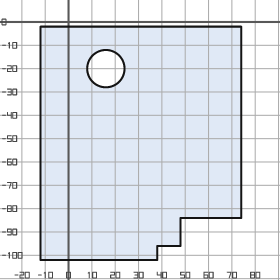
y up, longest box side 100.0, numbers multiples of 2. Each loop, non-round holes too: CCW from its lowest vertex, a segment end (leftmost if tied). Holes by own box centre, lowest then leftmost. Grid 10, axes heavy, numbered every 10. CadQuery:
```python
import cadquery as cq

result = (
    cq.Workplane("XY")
    .moveTo(-12.0, -102.0)
    .lineTo(38.0, -102.0)
    .lineTo(38.0, -96.0)
    .lineTo(48.0, -96.0)
    .lineTo(48.0, -84.0)
    .lineTo(74.0, -84.0)
    .lineTo(74.0, -2.0)
    .lineTo(-12.0, -2.0)
    .close()
    .moveTo(16.0, -20.0)
    .circle(8.0)
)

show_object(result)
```